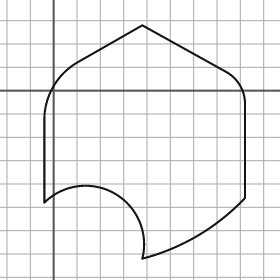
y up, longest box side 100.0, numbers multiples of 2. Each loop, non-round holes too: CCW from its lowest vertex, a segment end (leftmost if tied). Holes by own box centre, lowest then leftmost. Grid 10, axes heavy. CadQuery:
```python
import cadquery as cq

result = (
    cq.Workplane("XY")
    .moveTo(38.0, -72.0)
    .threePointArc((62.0, -62.0), (82.0, -46.0))
    .lineTo(82.0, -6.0)
    .threePointArc((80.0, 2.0), (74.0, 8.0))
    .lineTo(38.0, 28.0)
    .lineTo(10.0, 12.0)
    .threePointArc((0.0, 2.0), (-4.0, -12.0))
    .lineTo(-4.0, -48.0)
    .threePointArc((26.0, -44.0), (38.0, -72.0))
    .close()
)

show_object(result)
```